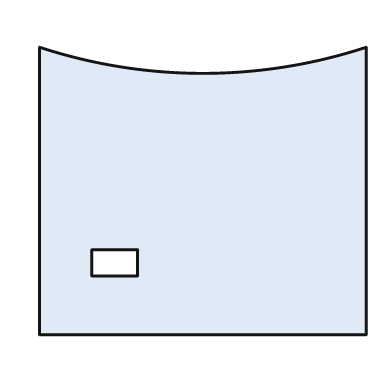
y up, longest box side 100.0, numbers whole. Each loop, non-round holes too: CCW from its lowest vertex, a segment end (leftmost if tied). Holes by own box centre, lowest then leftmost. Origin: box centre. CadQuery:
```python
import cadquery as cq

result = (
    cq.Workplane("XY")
    .moveTo(-50.0, -44.0)
    .lineTo(50.0, -44.0)
    .lineTo(50.0, 44.0)
    .threePointArc((0.0, 36.0), (-50.0, 44.0))
    .close()
    .moveTo(-34.0, -26.0)
    .lineTo(-20.0, -26.0)
    .lineTo(-20.0, -18.0)
    .lineTo(-34.0, -18.0)
    .close()
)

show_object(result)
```